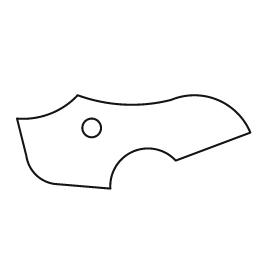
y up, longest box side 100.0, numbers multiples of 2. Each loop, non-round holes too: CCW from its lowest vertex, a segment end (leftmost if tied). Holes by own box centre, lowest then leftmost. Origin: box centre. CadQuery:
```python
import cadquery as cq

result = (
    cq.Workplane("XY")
    .moveTo(-10.0, -20.0)
    .threePointArc((0.0, -4.0), (18.0, -8.0))
    .lineTo(50.0, 4.0)
    .threePointArc((36.0, 18.0), (16.0, 18.0))
    .threePointArc((-4.0, 16.0), (-24.0, 20.0))
    .threePointArc((-36.0, 12.0), (-50.0, 10.0))
    .lineTo(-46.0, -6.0)
    .threePointArc((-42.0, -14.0), (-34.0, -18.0))
    .close()
    .moveTo(-18.0, 6.0)
    .circle(4.0)
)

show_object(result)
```